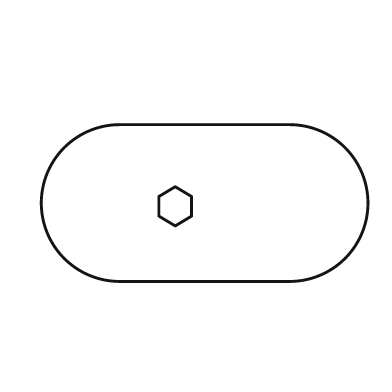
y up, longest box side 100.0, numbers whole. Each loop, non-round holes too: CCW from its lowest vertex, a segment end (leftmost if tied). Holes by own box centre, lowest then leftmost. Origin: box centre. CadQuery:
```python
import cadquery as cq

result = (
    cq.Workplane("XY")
    .moveTo(-26.0, -24.0)
    .lineTo(26.0, -24.0)
    .threePointArc((50.0, 0.0), (26.0, 24.0))
    .lineTo(-26.0, 24.0)
    .threePointArc((-50.0, 0.0), (-26.0, -24.0))
    .close()
    .moveTo(-9.0, -7.0)
    .lineTo(-4.0, -4.0)
    .lineTo(-4.0, 2.0)
    .lineTo(-9.0, 5.0)
    .lineTo(-14.0, 2.0)
    .lineTo(-14.0, -4.0)
    .close()
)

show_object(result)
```